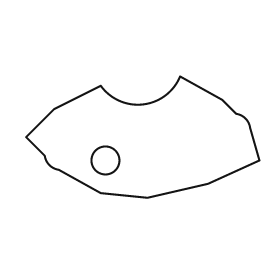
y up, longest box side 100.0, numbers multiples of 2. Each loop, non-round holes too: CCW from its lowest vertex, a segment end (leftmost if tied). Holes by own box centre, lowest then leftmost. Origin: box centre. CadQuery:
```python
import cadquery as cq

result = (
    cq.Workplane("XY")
    .moveTo(2.0, -26.0)
    .lineTo(28.0, -20.0)
    .lineTo(50.0, -10.0)
    .lineTo(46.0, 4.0)
    .threePointArc((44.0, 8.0), (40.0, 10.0))
    .lineTo(34.0, 16.0)
    .lineTo(16.0, 26.0)
    .threePointArc((0.0, 14.0), (-18.0, 22.0))
    .lineTo(-38.0, 12.0)
    .lineTo(-50.0, 0.0)
    .lineTo(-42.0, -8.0)
    .threePointArc((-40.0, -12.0), (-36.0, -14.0))
    .lineTo(-18.0, -24.0)
    .close()
    .moveTo(-16.0, -10.0)
    .circle(6.0)
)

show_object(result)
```